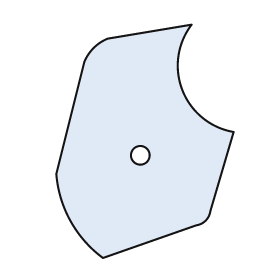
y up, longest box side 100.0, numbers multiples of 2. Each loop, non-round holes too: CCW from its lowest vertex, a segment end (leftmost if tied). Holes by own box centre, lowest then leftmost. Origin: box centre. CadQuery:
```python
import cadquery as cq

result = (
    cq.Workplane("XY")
    .moveTo(-18.0, -50.0)
    .lineTo(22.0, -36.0)
    .threePointArc((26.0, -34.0), (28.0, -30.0))
    .lineTo(38.0, 4.0)
    .threePointArc((16.0, 22.0), (20.0, 50.0))
    .lineTo(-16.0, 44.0)
    .threePointArc((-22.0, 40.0), (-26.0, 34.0))
    .lineTo(-38.0, -14.0)
    .threePointArc((-32.0, -34.0), (-18.0, -50.0))
    .close()
    .moveTo(-2.0, -6.0)
    .circle(4.0)
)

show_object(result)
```